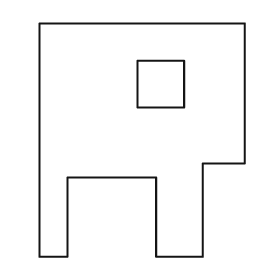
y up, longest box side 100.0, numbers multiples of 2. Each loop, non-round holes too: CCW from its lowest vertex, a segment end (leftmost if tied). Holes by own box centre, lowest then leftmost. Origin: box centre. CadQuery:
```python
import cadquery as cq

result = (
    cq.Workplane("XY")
    .moveTo(-44.0, -50.0)
    .lineTo(-32.0, -50.0)
    .lineTo(-32.0, -16.0)
    .lineTo(6.0, -16.0)
    .lineTo(6.0, -50.0)
    .lineTo(26.0, -50.0)
    .lineTo(26.0, -10.0)
    .lineTo(44.0, -10.0)
    .lineTo(44.0, 50.0)
    .lineTo(-44.0, 50.0)
    .close()
    .moveTo(-2.0, 14.0)
    .lineTo(18.0, 14.0)
    .lineTo(18.0, 34.0)
    .lineTo(-2.0, 34.0)
    .close()
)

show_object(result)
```